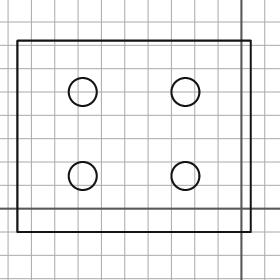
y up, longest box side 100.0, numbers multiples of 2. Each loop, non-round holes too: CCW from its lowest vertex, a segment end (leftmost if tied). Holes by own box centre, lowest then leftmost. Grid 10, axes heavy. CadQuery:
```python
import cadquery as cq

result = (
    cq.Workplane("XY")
    .moveTo(-96.0, -10.0)
    .lineTo(4.0, -10.0)
    .lineTo(4.0, 72.0)
    .lineTo(-96.0, 72.0)
    .close()
    .moveTo(-68.0, 14.0)
    .circle(6.0)
    .moveTo(-24.0, 14.0)
    .circle(6.0)
    .moveTo(-68.0, 50.0)
    .circle(6.0)
    .moveTo(-24.0, 50.0)
    .circle(6.0)
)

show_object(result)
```